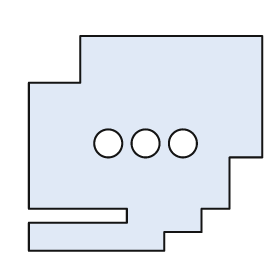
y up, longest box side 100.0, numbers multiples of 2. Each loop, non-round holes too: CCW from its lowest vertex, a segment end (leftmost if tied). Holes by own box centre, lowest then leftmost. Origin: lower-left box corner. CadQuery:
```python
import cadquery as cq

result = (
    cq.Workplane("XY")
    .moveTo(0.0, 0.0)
    .lineTo(58.0, 0.0)
    .lineTo(58.0, 8.0)
    .lineTo(74.0, 8.0)
    .lineTo(74.0, 18.0)
    .lineTo(86.0, 18.0)
    .lineTo(86.0, 40.0)
    .lineTo(100.0, 40.0)
    .lineTo(100.0, 92.0)
    .lineTo(22.0, 92.0)
    .lineTo(22.0, 72.0)
    .lineTo(0.0, 72.0)
    .lineTo(0.0, 18.0)
    .lineTo(42.0, 18.0)
    .lineTo(42.0, 12.0)
    .lineTo(0.0, 12.0)
    .close()
    .moveTo(34.0, 46.0)
    .circle(6.0)
    .moveTo(50.0, 46.0)
    .circle(6.0)
    .moveTo(66.0, 46.0)
    .circle(6.0)
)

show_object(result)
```